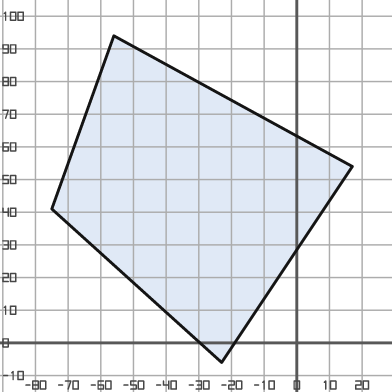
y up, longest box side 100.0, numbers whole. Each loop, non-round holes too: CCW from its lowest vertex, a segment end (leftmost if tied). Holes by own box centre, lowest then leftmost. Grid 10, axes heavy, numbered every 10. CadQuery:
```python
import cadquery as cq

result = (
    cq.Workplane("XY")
    .moveTo(-23.0, -6.0)
    .lineTo(17.0, 54.0)
    .lineTo(-56.0, 94.0)
    .lineTo(-75.0, 41.0)
    .close()
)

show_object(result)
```